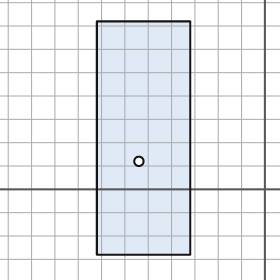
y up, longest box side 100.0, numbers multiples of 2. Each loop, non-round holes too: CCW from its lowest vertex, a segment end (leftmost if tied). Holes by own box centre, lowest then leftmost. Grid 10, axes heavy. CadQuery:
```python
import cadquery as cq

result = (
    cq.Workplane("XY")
    .moveTo(-72.0, -28.0)
    .lineTo(-32.0, -28.0)
    .lineTo(-32.0, 72.0)
    .lineTo(-72.0, 72.0)
    .close()
    .moveTo(-54.0, 12.0)
    .circle(2.0)
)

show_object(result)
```